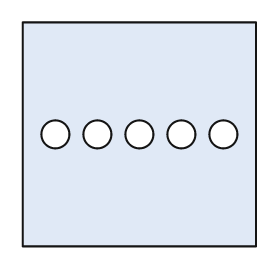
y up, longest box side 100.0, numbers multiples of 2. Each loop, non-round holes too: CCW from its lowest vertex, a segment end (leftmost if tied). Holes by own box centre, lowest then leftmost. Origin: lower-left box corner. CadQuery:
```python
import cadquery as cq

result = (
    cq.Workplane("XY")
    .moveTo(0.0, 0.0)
    .lineTo(100.0, 0.0)
    .lineTo(100.0, 96.0)
    .lineTo(0.0, 96.0)
    .close()
    .moveTo(14.0, 48.0)
    .circle(6.0)
    .moveTo(32.0, 48.0)
    .circle(6.0)
    .moveTo(50.0, 48.0)
    .circle(6.0)
    .moveTo(68.0, 48.0)
    .circle(6.0)
    .moveTo(86.0, 48.0)
    .circle(6.0)
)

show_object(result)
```